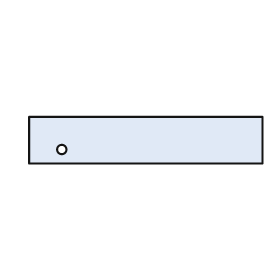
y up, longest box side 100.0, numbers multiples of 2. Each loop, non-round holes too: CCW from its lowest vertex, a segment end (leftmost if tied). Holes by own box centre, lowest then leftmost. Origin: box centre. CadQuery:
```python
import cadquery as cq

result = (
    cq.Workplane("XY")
    .moveTo(-50.0, -10.0)
    .lineTo(50.0, -10.0)
    .lineTo(50.0, 10.0)
    .lineTo(-50.0, 10.0)
    .close()
    .moveTo(-36.0, -4.0)
    .circle(2.0)
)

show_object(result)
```